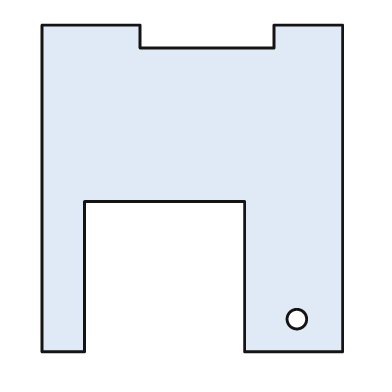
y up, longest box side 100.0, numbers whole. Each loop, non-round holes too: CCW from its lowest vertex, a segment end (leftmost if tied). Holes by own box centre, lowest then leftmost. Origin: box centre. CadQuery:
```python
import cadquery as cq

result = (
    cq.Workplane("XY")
    .moveTo(-46.0, -50.0)
    .lineTo(-33.0, -50.0)
    .lineTo(-33.0, -4.0)
    .lineTo(16.0, -4.0)
    .lineTo(16.0, -50.0)
    .lineTo(46.0, -50.0)
    .lineTo(46.0, 50.0)
    .lineTo(25.0, 50.0)
    .lineTo(25.0, 43.0)
    .lineTo(-16.0, 43.0)
    .lineTo(-16.0, 50.0)
    .lineTo(-46.0, 50.0)
    .close()
    .moveTo(32.0, -40.0)
    .circle(3.0)
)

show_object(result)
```